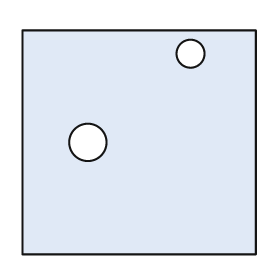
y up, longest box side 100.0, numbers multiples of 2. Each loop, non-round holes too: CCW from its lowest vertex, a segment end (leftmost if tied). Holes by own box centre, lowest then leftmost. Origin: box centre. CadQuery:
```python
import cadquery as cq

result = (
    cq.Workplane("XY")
    .moveTo(-50.0, -48.0)
    .lineTo(50.0, -48.0)
    .lineTo(50.0, 48.0)
    .lineTo(-50.0, 48.0)
    .close()
    .moveTo(-22.0, 0.0)
    .circle(8.0)
    .moveTo(22.0, 38.0)
    .circle(6.0)
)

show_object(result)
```